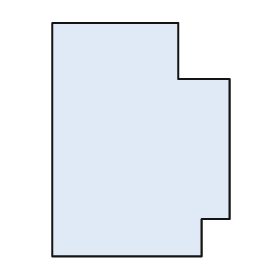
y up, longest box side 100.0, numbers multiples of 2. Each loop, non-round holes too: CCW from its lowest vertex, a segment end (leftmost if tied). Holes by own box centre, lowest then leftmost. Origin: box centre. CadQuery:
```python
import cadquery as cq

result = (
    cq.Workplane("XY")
    .moveTo(-38.0, -50.0)
    .lineTo(26.0, -50.0)
    .lineTo(26.0, -34.0)
    .lineTo(38.0, -34.0)
    .lineTo(38.0, 26.0)
    .lineTo(16.0, 26.0)
    .lineTo(16.0, 50.0)
    .lineTo(-38.0, 50.0)
    .close()
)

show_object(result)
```